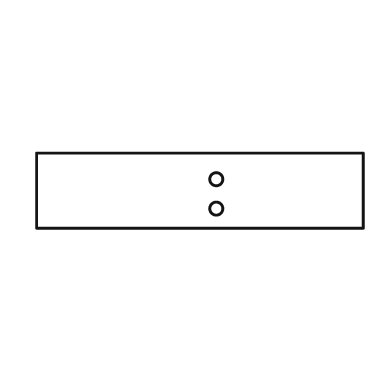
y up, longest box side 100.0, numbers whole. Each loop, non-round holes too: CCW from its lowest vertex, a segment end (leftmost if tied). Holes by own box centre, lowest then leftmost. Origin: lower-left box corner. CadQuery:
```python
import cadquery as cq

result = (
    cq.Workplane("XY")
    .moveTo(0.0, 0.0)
    .lineTo(100.0, 0.0)
    .lineTo(100.0, 23.0)
    .lineTo(0.0, 23.0)
    .close()
    .moveTo(55.0, 6.0)
    .circle(2.0)
    .moveTo(55.0, 15.0)
    .circle(2.0)
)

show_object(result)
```